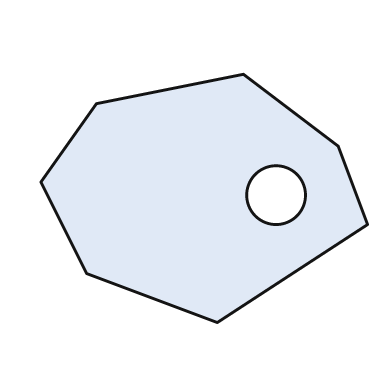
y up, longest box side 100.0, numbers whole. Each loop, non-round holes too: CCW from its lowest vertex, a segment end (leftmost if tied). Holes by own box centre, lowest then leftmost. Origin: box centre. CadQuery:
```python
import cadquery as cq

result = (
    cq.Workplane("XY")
    .moveTo(4.0, -38.0)
    .lineTo(50.0, -8.0)
    .lineTo(41.0, 16.0)
    .lineTo(12.0, 38.0)
    .lineTo(-33.0, 29.0)
    .lineTo(-50.0, 5.0)
    .lineTo(-36.0, -23.0)
    .close()
    .moveTo(22.0, 1.0)
    .circle(9.0)
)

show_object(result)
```